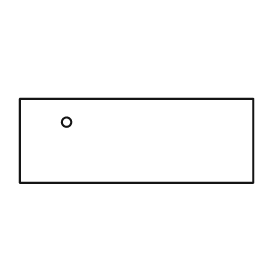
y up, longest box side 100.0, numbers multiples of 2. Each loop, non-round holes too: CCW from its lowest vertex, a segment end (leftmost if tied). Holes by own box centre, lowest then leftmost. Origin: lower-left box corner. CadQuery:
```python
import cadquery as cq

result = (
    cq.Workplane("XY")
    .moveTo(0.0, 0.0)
    .lineTo(100.0, 0.0)
    .lineTo(100.0, 36.0)
    .lineTo(0.0, 36.0)
    .close()
    .moveTo(20.0, 26.0)
    .circle(2.0)
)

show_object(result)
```